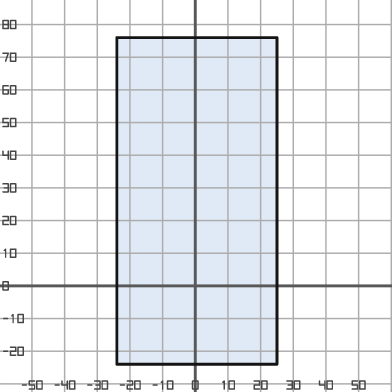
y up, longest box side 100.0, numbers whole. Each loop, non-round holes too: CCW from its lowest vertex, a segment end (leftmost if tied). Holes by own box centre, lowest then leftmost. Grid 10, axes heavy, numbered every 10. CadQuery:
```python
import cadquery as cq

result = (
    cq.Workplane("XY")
    .moveTo(-24.0, -24.0)
    .lineTo(25.0, -24.0)
    .lineTo(25.0, 76.0)
    .lineTo(-24.0, 76.0)
    .close()
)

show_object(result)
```